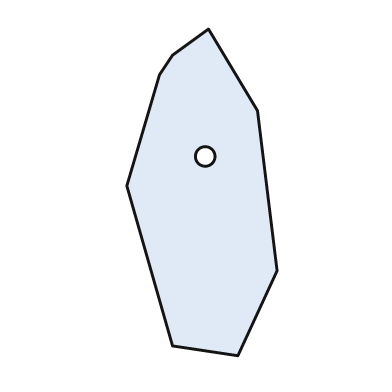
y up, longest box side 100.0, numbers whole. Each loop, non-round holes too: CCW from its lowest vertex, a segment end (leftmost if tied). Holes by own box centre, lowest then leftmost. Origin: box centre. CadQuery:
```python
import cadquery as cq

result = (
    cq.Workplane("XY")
    .moveTo(11.0, -50.0)
    .lineTo(23.0, -24.0)
    .lineTo(17.0, 25.0)
    .lineTo(2.0, 50.0)
    .lineTo(-9.0, 42.0)
    .lineTo(-13.0, 36.0)
    .lineTo(-23.0, 2.0)
    .lineTo(-9.0, -47.0)
    .close()
    .moveTo(1.0, 11.0)
    .circle(3.0)
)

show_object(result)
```